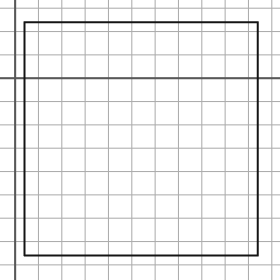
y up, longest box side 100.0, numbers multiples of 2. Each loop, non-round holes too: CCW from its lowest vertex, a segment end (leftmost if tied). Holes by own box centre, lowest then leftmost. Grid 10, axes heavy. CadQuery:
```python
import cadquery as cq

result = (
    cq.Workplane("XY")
    .moveTo(4.0, -76.0)
    .lineTo(104.0, -76.0)
    .lineTo(104.0, 24.0)
    .lineTo(4.0, 24.0)
    .close()
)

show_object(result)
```